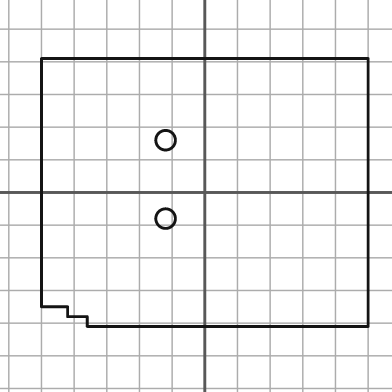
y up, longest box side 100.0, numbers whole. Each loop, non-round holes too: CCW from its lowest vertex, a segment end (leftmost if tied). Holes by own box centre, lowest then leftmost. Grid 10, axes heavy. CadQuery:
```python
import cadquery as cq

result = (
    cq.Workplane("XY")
    .moveTo(-36.0, -41.0)
    .lineTo(50.0, -41.0)
    .lineTo(50.0, 41.0)
    .lineTo(-50.0, 41.0)
    .lineTo(-50.0, -35.0)
    .lineTo(-42.0, -35.0)
    .lineTo(-42.0, -38.0)
    .lineTo(-36.0, -38.0)
    .close()
    .moveTo(-12.0, -8.0)
    .circle(3.0)
    .moveTo(-12.0, 16.0)
    .circle(3.0)
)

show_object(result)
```